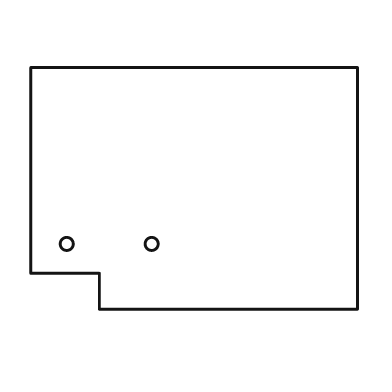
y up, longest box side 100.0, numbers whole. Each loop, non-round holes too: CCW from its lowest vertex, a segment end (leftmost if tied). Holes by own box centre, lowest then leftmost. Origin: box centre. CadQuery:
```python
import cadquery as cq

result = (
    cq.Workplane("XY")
    .moveTo(-29.0, -37.0)
    .lineTo(50.0, -37.0)
    .lineTo(50.0, 37.0)
    .lineTo(-50.0, 37.0)
    .lineTo(-50.0, -26.0)
    .lineTo(-29.0, -26.0)
    .close()
    .moveTo(-39.0, -17.0)
    .circle(2.0)
    .moveTo(-13.0, -17.0)
    .circle(2.0)
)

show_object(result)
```